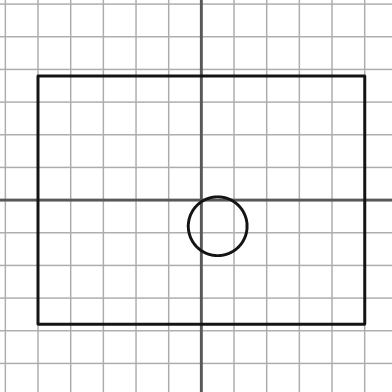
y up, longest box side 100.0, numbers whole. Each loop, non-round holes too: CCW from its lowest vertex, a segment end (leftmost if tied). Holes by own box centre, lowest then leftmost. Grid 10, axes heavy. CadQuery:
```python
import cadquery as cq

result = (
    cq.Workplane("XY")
    .moveTo(-50.0, -38.0)
    .lineTo(50.0, -38.0)
    .lineTo(50.0, 38.0)
    .lineTo(-50.0, 38.0)
    .close()
    .moveTo(5.0, -8.0)
    .circle(9.0)
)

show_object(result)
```